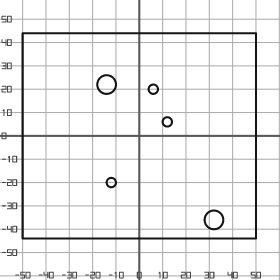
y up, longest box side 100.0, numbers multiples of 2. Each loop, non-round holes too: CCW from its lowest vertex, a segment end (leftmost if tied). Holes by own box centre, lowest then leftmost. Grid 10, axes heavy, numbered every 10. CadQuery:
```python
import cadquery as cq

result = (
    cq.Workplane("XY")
    .moveTo(-50.0, -44.0)
    .lineTo(50.0, -44.0)
    .lineTo(50.0, 44.0)
    .lineTo(-50.0, 44.0)
    .close()
    .moveTo(32.0, -36.0)
    .circle(4.0)
    .moveTo(-12.0, -20.0)
    .circle(2.0)
    .moveTo(12.0, 6.0)
    .circle(2.0)
    .moveTo(6.0, 20.0)
    .circle(2.0)
    .moveTo(-14.0, 22.0)
    .circle(4.0)
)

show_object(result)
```